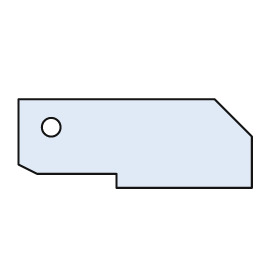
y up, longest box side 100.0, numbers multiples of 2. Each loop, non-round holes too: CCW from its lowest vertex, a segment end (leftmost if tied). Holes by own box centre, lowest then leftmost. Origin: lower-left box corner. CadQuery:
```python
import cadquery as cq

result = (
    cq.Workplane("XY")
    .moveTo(42.0, 0.0)
    .lineTo(100.0, 0.0)
    .lineTo(100.0, 22.0)
    .lineTo(84.0, 38.0)
    .lineTo(0.0, 38.0)
    .lineTo(0.0, 10.0)
    .lineTo(8.0, 6.0)
    .lineTo(42.0, 6.0)
    .close()
    .moveTo(14.0, 26.0)
    .circle(4.0)
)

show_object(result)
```